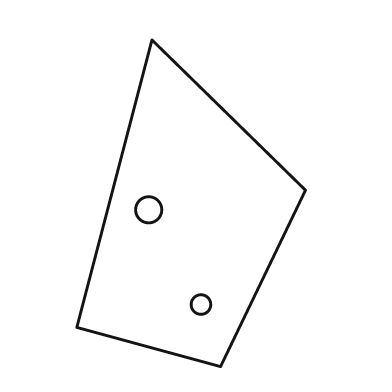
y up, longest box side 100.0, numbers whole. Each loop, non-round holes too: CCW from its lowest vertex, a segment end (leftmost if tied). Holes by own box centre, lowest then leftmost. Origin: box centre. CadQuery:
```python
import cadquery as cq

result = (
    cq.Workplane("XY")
    .moveTo(9.0, -50.0)
    .lineTo(35.0, 4.0)
    .lineTo(-12.0, 50.0)
    .lineTo(-35.0, -38.0)
    .close()
    .moveTo(3.0, -31.0)
    .circle(3.0)
    .moveTo(-13.0, -2.0)
    .circle(4.0)
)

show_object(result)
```